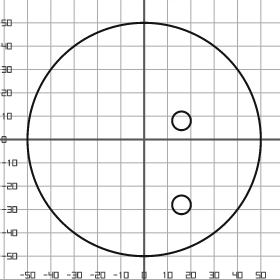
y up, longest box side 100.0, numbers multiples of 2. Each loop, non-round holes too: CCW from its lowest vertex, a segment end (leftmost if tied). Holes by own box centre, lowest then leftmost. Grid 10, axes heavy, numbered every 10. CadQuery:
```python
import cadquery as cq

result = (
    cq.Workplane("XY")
    .moveTo(0.0, 0.0)
    .circle(50.0)
    .moveTo(16.0, -28.0)
    .circle(4.0)
    .moveTo(16.0, 8.0)
    .circle(4.0)
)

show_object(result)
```